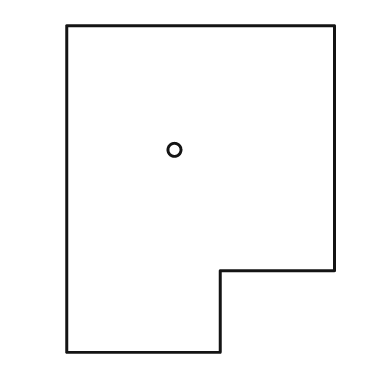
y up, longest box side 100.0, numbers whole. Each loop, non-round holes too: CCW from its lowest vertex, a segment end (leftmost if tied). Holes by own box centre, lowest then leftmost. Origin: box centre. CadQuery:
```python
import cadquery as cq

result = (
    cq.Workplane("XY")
    .moveTo(-41.0, -50.0)
    .lineTo(6.0, -50.0)
    .lineTo(6.0, -25.0)
    .lineTo(41.0, -25.0)
    .lineTo(41.0, 50.0)
    .lineTo(-41.0, 50.0)
    .close()
    .moveTo(-8.0, 12.0)
    .circle(2.0)
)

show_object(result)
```